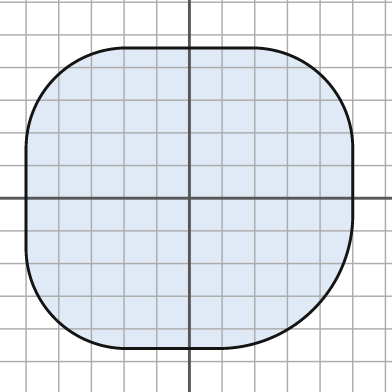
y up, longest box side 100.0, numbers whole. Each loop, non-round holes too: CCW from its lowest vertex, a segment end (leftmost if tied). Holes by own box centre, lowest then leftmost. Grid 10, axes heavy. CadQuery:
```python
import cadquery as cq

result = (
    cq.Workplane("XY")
    .moveTo(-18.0, -46.0)
    .lineTo(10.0, -46.0)
    .threePointArc((38.0, -34.0), (50.0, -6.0))
    .lineTo(50.0, 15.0)
    .threePointArc((41.0, 37.0), (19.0, 46.0))
    .lineTo(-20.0, 46.0)
    .threePointArc((-41.0, 37.0), (-50.0, 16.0))
    .lineTo(-50.0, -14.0)
    .threePointArc((-41.0, -37.0), (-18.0, -46.0))
    .close()
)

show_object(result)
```